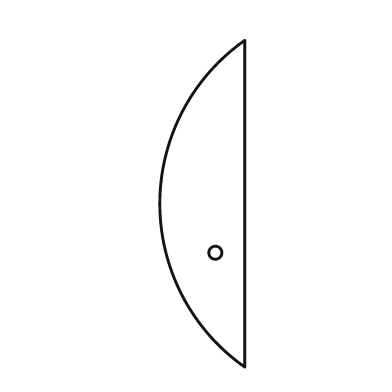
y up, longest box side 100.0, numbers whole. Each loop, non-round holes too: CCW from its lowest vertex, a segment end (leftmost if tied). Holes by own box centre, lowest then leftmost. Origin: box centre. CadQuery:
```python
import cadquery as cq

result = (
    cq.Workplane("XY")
    .moveTo(13.0, -50.0)
    .lineTo(13.0, 50.0)
    .threePointArc((-13.0, 0.0), (13.0, -50.0))
    .close()
    .moveTo(4.0, -15.0)
    .circle(2.0)
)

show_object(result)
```